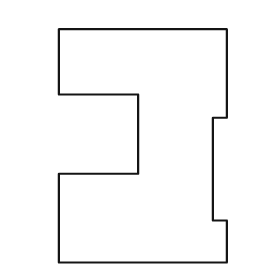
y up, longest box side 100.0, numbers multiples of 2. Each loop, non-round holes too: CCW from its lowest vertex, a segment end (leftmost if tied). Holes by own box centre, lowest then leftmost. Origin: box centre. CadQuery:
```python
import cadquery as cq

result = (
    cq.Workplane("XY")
    .moveTo(-36.0, -50.0)
    .lineTo(36.0, -50.0)
    .lineTo(36.0, -32.0)
    .lineTo(30.0, -32.0)
    .lineTo(30.0, 12.0)
    .lineTo(36.0, 12.0)
    .lineTo(36.0, 50.0)
    .lineTo(-36.0, 50.0)
    .lineTo(-36.0, 22.0)
    .lineTo(-2.0, 22.0)
    .lineTo(-2.0, -12.0)
    .lineTo(-36.0, -12.0)
    .close()
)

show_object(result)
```